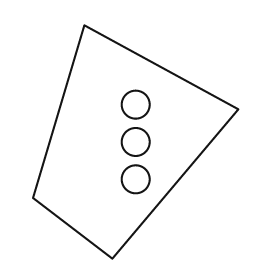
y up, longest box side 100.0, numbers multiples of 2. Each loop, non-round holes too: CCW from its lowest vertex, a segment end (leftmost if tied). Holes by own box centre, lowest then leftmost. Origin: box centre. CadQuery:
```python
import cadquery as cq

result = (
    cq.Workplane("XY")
    .moveTo(-10.0, -50.0)
    .lineTo(44.0, 14.0)
    .lineTo(-22.0, 50.0)
    .lineTo(-44.0, -24.0)
    .close()
    .moveTo(0.0, -16.0)
    .circle(6.0)
    .moveTo(0.0, 0.0)
    .circle(6.0)
    .moveTo(0.0, 16.0)
    .circle(6.0)
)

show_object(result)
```